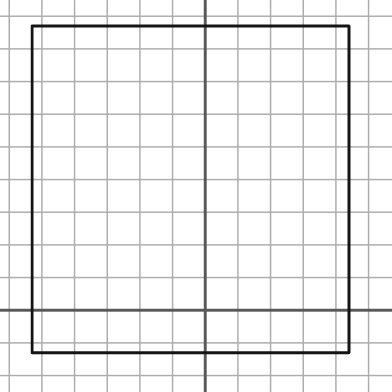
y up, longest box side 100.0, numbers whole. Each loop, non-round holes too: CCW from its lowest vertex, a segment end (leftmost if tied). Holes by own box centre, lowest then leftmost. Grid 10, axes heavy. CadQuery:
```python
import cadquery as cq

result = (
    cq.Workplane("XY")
    .moveTo(-53.0, -13.0)
    .lineTo(44.0, -13.0)
    .lineTo(44.0, 87.0)
    .lineTo(-53.0, 87.0)
    .close()
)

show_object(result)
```